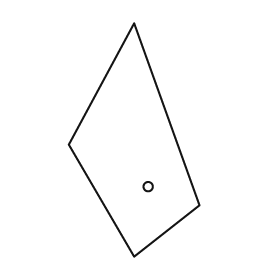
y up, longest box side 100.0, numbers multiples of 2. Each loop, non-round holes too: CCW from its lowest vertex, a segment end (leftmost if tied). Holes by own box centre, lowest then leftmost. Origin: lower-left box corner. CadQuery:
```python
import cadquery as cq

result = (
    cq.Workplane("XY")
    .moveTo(28.0, 0.0)
    .lineTo(56.0, 22.0)
    .lineTo(28.0, 100.0)
    .lineTo(0.0, 48.0)
    .close()
    .moveTo(34.0, 30.0)
    .circle(2.0)
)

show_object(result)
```